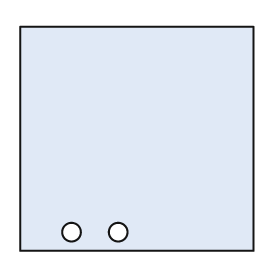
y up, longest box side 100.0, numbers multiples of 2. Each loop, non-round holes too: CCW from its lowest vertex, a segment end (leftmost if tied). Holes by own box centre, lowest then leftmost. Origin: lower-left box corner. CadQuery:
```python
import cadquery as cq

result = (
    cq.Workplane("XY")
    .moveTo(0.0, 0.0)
    .lineTo(100.0, 0.0)
    .lineTo(100.0, 96.0)
    .lineTo(0.0, 96.0)
    .close()
    .moveTo(22.0, 8.0)
    .circle(4.0)
    .moveTo(42.0, 8.0)
    .circle(4.0)
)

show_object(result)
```